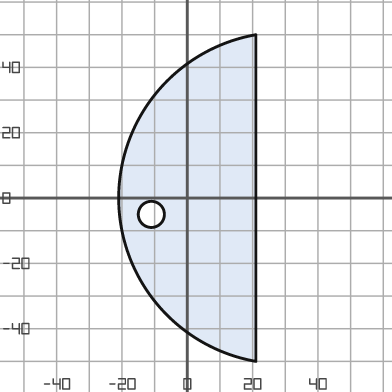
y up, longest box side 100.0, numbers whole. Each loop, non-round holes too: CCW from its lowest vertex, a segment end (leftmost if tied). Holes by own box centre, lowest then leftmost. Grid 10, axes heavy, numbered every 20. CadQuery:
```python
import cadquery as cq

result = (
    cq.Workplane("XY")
    .moveTo(21.0, -50.0)
    .lineTo(21.0, 50.0)
    .threePointArc((-21.0, 0.0), (21.0, -50.0))
    .close()
    .moveTo(-11.0, -5.0)
    .circle(4.0)
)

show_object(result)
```